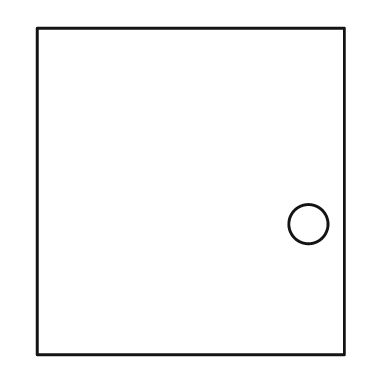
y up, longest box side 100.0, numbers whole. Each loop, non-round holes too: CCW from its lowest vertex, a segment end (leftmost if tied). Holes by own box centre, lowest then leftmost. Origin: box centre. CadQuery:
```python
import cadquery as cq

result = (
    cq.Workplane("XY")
    .moveTo(-47.0, -50.0)
    .lineTo(47.0, -50.0)
    .lineTo(47.0, 50.0)
    .lineTo(-47.0, 50.0)
    .close()
    .moveTo(36.0, -10.0)
    .circle(6.0)
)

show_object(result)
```